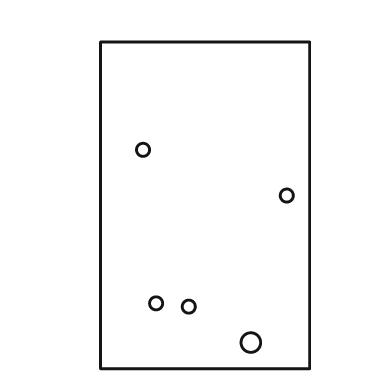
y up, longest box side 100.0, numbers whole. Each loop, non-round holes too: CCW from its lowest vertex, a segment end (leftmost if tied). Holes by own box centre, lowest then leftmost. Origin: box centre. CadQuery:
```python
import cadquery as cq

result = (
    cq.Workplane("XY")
    .moveTo(-32.0, -50.0)
    .lineTo(32.0, -50.0)
    .lineTo(32.0, 50.0)
    .lineTo(-32.0, 50.0)
    .close()
    .moveTo(14.0, -42.0)
    .circle(3.0)
    .moveTo(-5.0, -31.0)
    .circle(2.0)
    .moveTo(-15.0, -30.0)
    .circle(2.0)
    .moveTo(25.0, 3.0)
    .circle(2.0)
    .moveTo(-19.0, 17.0)
    .circle(2.0)
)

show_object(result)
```